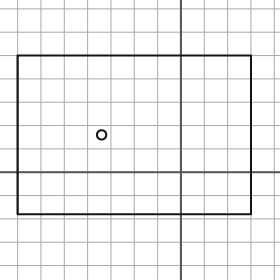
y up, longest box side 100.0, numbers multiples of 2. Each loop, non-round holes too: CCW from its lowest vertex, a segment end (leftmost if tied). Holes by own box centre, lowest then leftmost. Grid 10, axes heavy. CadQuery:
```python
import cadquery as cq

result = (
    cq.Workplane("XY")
    .moveTo(-70.0, -18.0)
    .lineTo(30.0, -18.0)
    .lineTo(30.0, 50.0)
    .lineTo(-70.0, 50.0)
    .close()
    .moveTo(-34.0, 16.0)
    .circle(2.0)
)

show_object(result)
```